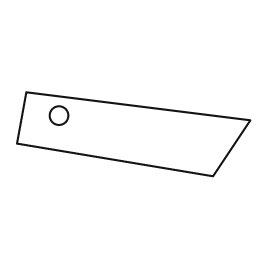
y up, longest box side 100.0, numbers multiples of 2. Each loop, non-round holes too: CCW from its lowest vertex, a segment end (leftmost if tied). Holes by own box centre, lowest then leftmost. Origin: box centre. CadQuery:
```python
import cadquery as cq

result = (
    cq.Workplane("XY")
    .moveTo(34.0, -18.0)
    .lineTo(50.0, 6.0)
    .lineTo(-46.0, 18.0)
    .lineTo(-50.0, -4.0)
    .close()
    .moveTo(-32.0, 8.0)
    .circle(4.0)
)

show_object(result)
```